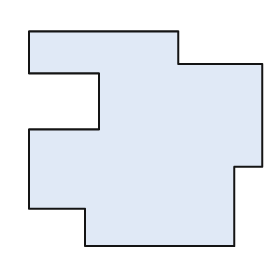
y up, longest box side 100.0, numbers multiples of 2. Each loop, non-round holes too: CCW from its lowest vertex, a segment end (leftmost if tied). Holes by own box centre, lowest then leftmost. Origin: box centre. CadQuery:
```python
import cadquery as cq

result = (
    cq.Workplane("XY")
    .moveTo(-26.0, -46.0)
    .lineTo(38.0, -46.0)
    .lineTo(38.0, -12.0)
    .lineTo(50.0, -12.0)
    .lineTo(50.0, 32.0)
    .lineTo(14.0, 32.0)
    .lineTo(14.0, 46.0)
    .lineTo(-50.0, 46.0)
    .lineTo(-50.0, 28.0)
    .lineTo(-20.0, 28.0)
    .lineTo(-20.0, 4.0)
    .lineTo(-50.0, 4.0)
    .lineTo(-50.0, -30.0)
    .lineTo(-26.0, -30.0)
    .close()
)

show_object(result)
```